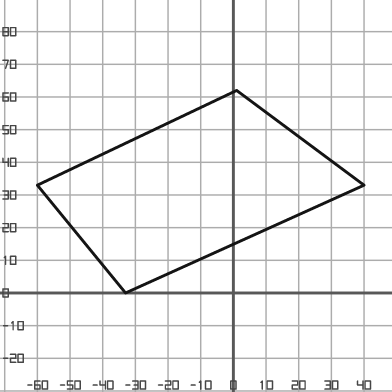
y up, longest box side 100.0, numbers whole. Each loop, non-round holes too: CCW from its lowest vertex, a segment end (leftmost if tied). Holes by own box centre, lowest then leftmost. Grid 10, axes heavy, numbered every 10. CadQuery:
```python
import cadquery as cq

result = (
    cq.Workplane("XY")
    .moveTo(-33.0, 0.0)
    .lineTo(40.0, 33.0)
    .lineTo(1.0, 62.0)
    .lineTo(-60.0, 33.0)
    .close()
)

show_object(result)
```